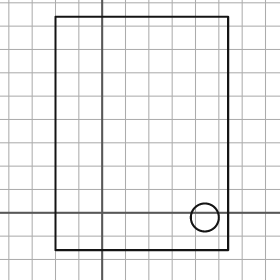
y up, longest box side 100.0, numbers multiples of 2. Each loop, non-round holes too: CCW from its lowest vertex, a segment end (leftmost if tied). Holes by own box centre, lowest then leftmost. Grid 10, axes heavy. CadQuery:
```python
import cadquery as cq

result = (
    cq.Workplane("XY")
    .moveTo(-20.0, -16.0)
    .lineTo(54.0, -16.0)
    .lineTo(54.0, 84.0)
    .lineTo(-20.0, 84.0)
    .close()
    .moveTo(44.0, -2.0)
    .circle(6.0)
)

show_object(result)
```